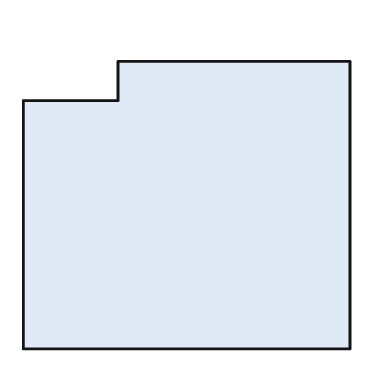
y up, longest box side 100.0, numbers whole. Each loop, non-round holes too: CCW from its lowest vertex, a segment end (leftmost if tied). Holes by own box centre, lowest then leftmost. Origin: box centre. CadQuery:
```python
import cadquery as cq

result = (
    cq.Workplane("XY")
    .moveTo(-50.0, -44.0)
    .lineTo(50.0, -44.0)
    .lineTo(50.0, 44.0)
    .lineTo(-21.0, 44.0)
    .lineTo(-21.0, 32.0)
    .lineTo(-50.0, 32.0)
    .close()
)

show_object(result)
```